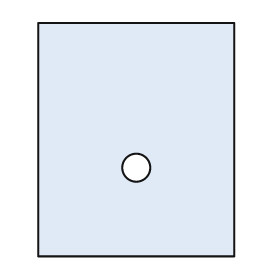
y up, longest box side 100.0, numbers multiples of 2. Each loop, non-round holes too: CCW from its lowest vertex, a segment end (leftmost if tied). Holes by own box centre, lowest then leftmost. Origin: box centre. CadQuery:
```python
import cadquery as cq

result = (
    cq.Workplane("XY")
    .moveTo(-42.0, -50.0)
    .lineTo(42.0, -50.0)
    .lineTo(42.0, 50.0)
    .lineTo(-42.0, 50.0)
    .close()
    .moveTo(0.0, -12.0)
    .circle(6.0)
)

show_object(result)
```